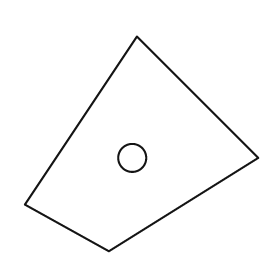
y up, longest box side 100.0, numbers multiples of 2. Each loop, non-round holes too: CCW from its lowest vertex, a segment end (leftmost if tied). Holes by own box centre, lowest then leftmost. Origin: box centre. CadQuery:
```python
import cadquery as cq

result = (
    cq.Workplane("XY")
    .moveTo(-14.0, -46.0)
    .lineTo(50.0, -6.0)
    .lineTo(-2.0, 46.0)
    .lineTo(-50.0, -26.0)
    .close()
    .moveTo(-4.0, -6.0)
    .circle(6.0)
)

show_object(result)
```